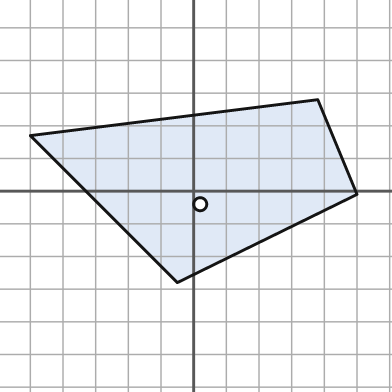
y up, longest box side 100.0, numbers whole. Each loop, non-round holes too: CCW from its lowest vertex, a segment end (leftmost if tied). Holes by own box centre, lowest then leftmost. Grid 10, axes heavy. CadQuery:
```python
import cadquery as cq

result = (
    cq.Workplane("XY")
    .moveTo(-5.0, -28.0)
    .lineTo(50.0, -1.0)
    .lineTo(38.0, 28.0)
    .lineTo(-50.0, 17.0)
    .close()
    .moveTo(2.0, -4.0)
    .circle(2.0)
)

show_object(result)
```